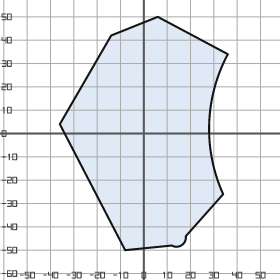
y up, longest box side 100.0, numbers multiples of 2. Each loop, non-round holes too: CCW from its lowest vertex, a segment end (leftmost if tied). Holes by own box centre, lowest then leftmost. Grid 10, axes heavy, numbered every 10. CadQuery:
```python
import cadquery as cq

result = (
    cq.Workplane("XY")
    .moveTo(-8.0, -50.0)
    .lineTo(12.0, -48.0)
    .threePointArc((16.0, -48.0), (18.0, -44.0))
    .lineTo(34.0, -26.0)
    .threePointArc((28.0, 4.0), (36.0, 34.0))
    .lineTo(6.0, 50.0)
    .lineTo(-14.0, 42.0)
    .lineTo(-36.0, 4.0)
    .close()
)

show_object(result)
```